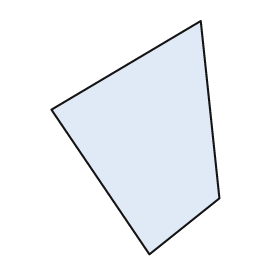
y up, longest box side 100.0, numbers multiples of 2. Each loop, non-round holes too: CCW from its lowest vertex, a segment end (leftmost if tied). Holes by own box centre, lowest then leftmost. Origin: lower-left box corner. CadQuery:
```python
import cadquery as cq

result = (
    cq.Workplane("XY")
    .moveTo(42.0, 0.0)
    .lineTo(72.0, 24.0)
    .lineTo(64.0, 100.0)
    .lineTo(0.0, 62.0)
    .close()
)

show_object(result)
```